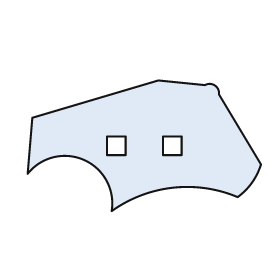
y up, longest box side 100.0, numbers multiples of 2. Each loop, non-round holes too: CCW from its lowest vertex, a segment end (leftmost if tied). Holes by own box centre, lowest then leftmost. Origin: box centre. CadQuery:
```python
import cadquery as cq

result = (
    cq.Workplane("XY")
    .moveTo(-14.0, -28.0)
    .threePointArc((12.0, -18.0), (40.0, -22.0))
    .threePointArc((46.0, -16.0), (50.0, -8.0))
    .lineTo(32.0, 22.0)
    .threePointArc((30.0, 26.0), (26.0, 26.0))
    .lineTo(6.0, 28.0)
    .lineTo(-48.0, 12.0)
    .lineTo(-50.0, -12.0)
    .threePointArc((-26.0, -6.0), (-14.0, -28.0))
    .close()
    .moveTo(-16.0, -4.0)
    .lineTo(-8.0, -4.0)
    .lineTo(-8.0, 4.0)
    .lineTo(-16.0, 4.0)
    .close()
    .moveTo(8.0, -4.0)
    .lineTo(16.0, -4.0)
    .lineTo(16.0, 4.0)
    .lineTo(8.0, 4.0)
    .close()
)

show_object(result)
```